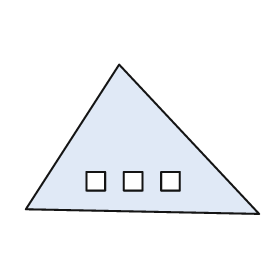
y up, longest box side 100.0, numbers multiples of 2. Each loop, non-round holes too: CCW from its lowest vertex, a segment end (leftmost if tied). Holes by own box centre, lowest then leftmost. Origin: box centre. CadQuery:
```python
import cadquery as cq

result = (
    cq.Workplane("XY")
    .moveTo(50.0, -32.0)
    .lineTo(-10.0, 32.0)
    .lineTo(-50.0, -30.0)
    .close()
    .moveTo(-24.0, -22.0)
    .lineTo(-16.0, -22.0)
    .lineTo(-16.0, -14.0)
    .lineTo(-24.0, -14.0)
    .close()
    .moveTo(-8.0, -22.0)
    .lineTo(0.0, -22.0)
    .lineTo(0.0, -14.0)
    .lineTo(-8.0, -14.0)
    .close()
    .moveTo(8.0, -22.0)
    .lineTo(16.0, -22.0)
    .lineTo(16.0, -14.0)
    .lineTo(8.0, -14.0)
    .close()
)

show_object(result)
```